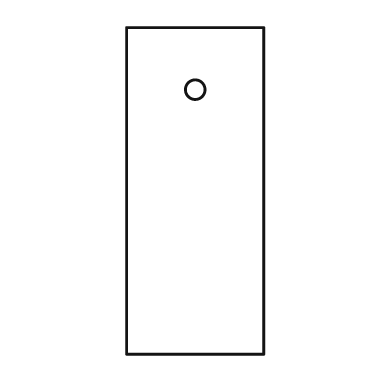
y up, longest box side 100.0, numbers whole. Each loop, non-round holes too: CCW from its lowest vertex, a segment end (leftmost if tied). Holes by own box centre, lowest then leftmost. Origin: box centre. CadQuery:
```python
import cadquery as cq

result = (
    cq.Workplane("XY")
    .moveTo(-21.0, -50.0)
    .lineTo(21.0, -50.0)
    .lineTo(21.0, 50.0)
    .lineTo(-21.0, 50.0)
    .close()
    .moveTo(0.0, 31.0)
    .circle(3.0)
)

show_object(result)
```